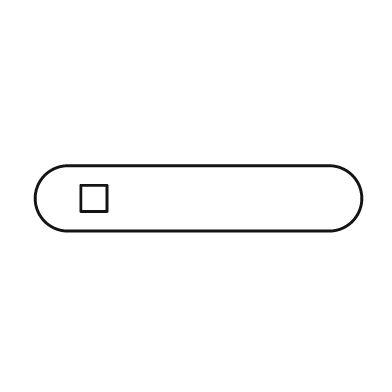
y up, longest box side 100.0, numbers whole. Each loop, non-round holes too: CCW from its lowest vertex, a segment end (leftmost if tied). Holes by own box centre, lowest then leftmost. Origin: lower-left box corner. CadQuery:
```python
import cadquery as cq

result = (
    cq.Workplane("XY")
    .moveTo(10.0, 0.0)
    .lineTo(90.0, 0.0)
    .threePointArc((100.0, 10.0), (90.0, 20.0))
    .lineTo(10.0, 20.0)
    .threePointArc((0.0, 10.0), (10.0, 0.0))
    .close()
    .moveTo(14.0, 6.0)
    .lineTo(22.0, 6.0)
    .lineTo(22.0, 14.0)
    .lineTo(14.0, 14.0)
    .close()
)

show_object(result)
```